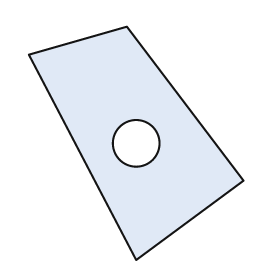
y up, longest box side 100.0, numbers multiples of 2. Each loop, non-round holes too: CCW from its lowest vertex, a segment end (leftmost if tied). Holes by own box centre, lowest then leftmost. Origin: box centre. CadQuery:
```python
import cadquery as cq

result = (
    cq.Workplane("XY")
    .moveTo(0.0, -50.0)
    .lineTo(46.0, -16.0)
    .lineTo(-4.0, 50.0)
    .lineTo(-46.0, 38.0)
    .close()
    .moveTo(0.0, 0.0)
    .circle(10.0)
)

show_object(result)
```